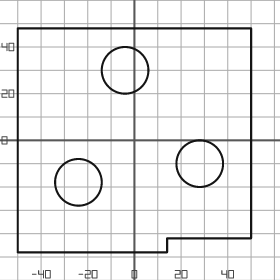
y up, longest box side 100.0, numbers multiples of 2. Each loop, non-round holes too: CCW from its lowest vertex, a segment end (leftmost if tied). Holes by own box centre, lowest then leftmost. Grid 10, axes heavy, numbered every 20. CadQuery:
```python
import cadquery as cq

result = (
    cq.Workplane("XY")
    .moveTo(-50.0, -48.0)
    .lineTo(14.0, -48.0)
    .lineTo(14.0, -42.0)
    .lineTo(50.0, -42.0)
    .lineTo(50.0, 48.0)
    .lineTo(-50.0, 48.0)
    .close()
    .moveTo(-24.0, -18.0)
    .circle(10.0)
    .moveTo(28.0, -10.0)
    .circle(10.0)
    .moveTo(-4.0, 30.0)
    .circle(10.0)
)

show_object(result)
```